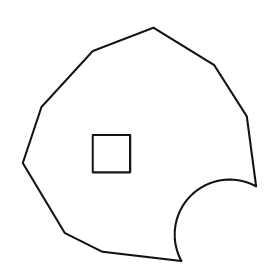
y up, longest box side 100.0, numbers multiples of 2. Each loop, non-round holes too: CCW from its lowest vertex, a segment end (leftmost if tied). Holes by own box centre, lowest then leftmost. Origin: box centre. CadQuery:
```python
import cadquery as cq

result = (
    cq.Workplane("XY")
    .moveTo(18.0, -50.0)
    .threePointArc((22.0, -22.0), (50.0, -18.0))
    .lineTo(46.0, 12.0)
    .lineTo(32.0, 34.0)
    .lineTo(6.0, 50.0)
    .lineTo(-20.0, 40.0)
    .lineTo(-42.0, 16.0)
    .lineTo(-50.0, -8.0)
    .lineTo(-32.0, -38.0)
    .lineTo(-16.0, -46.0)
    .close()
    .moveTo(-20.0, -12.0)
    .lineTo(-4.0, -12.0)
    .lineTo(-4.0, 4.0)
    .lineTo(-20.0, 4.0)
    .close()
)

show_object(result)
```